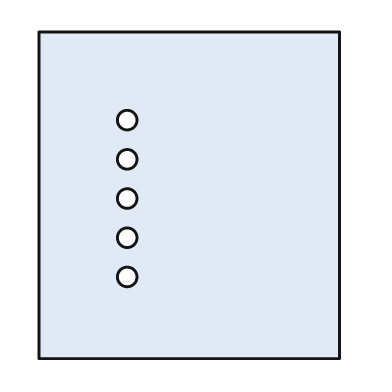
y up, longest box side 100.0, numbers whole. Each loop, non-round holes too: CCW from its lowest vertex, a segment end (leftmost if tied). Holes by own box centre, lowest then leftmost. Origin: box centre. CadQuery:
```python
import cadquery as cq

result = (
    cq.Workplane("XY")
    .moveTo(-46.0, -50.0)
    .lineTo(46.0, -50.0)
    .lineTo(46.0, 50.0)
    .lineTo(-46.0, 50.0)
    .close()
    .moveTo(-19.0, -25.0)
    .circle(3.0)
    .moveTo(-19.0, -13.0)
    .circle(3.0)
    .moveTo(-19.0, -1.0)
    .circle(3.0)
    .moveTo(-19.0, 11.0)
    .circle(3.0)
    .moveTo(-19.0, 23.0)
    .circle(3.0)
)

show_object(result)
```